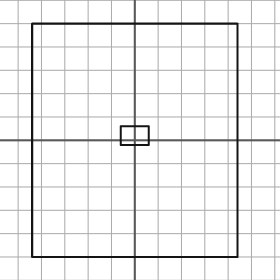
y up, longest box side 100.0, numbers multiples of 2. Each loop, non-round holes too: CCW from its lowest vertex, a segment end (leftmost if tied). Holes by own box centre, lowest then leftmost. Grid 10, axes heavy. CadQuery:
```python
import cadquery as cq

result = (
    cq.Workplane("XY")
    .moveTo(-44.0, -50.0)
    .lineTo(44.0, -50.0)
    .lineTo(44.0, 50.0)
    .lineTo(-44.0, 50.0)
    .close()
    .moveTo(-6.0, -2.0)
    .lineTo(6.0, -2.0)
    .lineTo(6.0, 6.0)
    .lineTo(-6.0, 6.0)
    .close()
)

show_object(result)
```